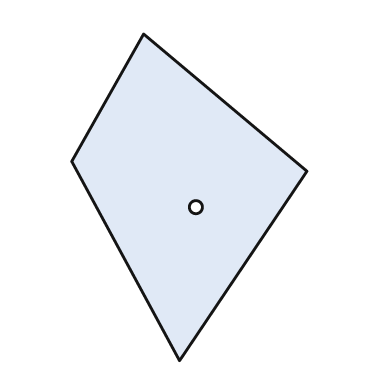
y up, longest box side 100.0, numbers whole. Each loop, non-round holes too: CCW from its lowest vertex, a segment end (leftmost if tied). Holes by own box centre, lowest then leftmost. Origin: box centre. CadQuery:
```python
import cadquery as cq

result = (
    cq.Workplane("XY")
    .moveTo(-3.0, -50.0)
    .lineTo(36.0, 8.0)
    .lineTo(-14.0, 50.0)
    .lineTo(-36.0, 11.0)
    .close()
    .moveTo(2.0, -3.0)
    .circle(2.0)
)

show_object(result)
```